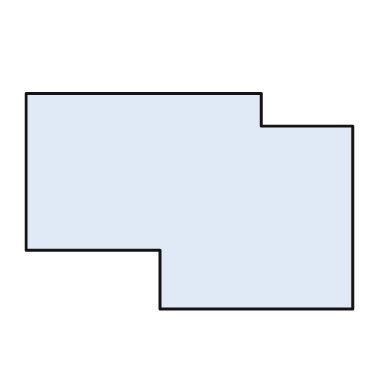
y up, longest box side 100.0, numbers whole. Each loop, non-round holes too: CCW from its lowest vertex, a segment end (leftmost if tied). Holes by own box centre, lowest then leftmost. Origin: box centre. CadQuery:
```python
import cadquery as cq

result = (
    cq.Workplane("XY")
    .moveTo(-9.0, -33.0)
    .lineTo(50.0, -33.0)
    .lineTo(50.0, 23.0)
    .lineTo(22.0, 23.0)
    .lineTo(22.0, 33.0)
    .lineTo(-50.0, 33.0)
    .lineTo(-50.0, -15.0)
    .lineTo(-9.0, -15.0)
    .close()
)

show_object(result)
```